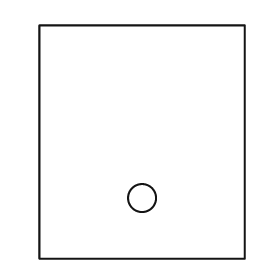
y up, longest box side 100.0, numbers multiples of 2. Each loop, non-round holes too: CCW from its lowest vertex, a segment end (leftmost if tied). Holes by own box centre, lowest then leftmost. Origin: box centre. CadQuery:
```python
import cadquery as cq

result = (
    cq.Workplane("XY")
    .moveTo(-44.0, -50.0)
    .lineTo(44.0, -50.0)
    .lineTo(44.0, 50.0)
    .lineTo(-44.0, 50.0)
    .close()
    .moveTo(0.0, -24.0)
    .circle(6.0)
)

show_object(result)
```